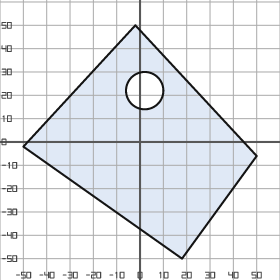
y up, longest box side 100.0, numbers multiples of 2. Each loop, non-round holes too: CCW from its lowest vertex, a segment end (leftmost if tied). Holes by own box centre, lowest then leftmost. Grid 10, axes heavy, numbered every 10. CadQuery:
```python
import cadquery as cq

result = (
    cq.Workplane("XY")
    .moveTo(18.0, -50.0)
    .lineTo(50.0, -6.0)
    .lineTo(-2.0, 50.0)
    .lineTo(-50.0, -2.0)
    .close()
    .moveTo(2.0, 22.0)
    .circle(8.0)
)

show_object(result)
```